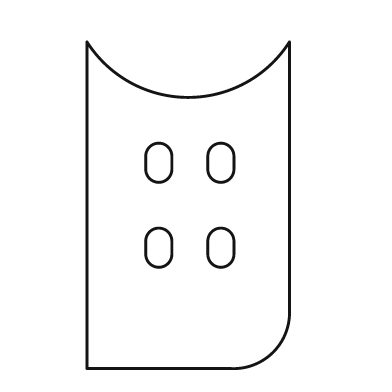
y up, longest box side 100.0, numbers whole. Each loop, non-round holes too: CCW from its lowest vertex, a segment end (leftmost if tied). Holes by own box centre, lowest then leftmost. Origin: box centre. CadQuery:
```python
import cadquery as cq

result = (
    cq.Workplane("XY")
    .moveTo(-31.0, -50.0)
    .lineTo(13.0, -50.0)
    .threePointArc((26.0, -45.0), (31.0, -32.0))
    .lineTo(31.0, 50.0)
    .threePointArc((0.0, 33.0), (-31.0, 50.0))
    .close()
    .moveTo(-13.0, -15.0)
    .threePointArc((-9.0, -19.0), (-5.0, -15.0))
    .lineTo(-5.0, -11.0)
    .threePointArc((-9.0, -7.0), (-13.0, -11.0))
    .close()
    .moveTo(6.0, -15.0)
    .threePointArc((10.0, -19.0), (14.0, -15.0))
    .lineTo(14.0, -11.0)
    .threePointArc((10.0, -7.0), (6.0, -11.0))
    .close()
    .moveTo(-13.0, 11.0)
    .threePointArc((-9.0, 7.0), (-5.0, 11.0))
    .lineTo(-5.0, 15.0)
    .threePointArc((-9.0, 19.0), (-13.0, 15.0))
    .close()
    .moveTo(6.0, 11.0)
    .threePointArc((10.0, 7.0), (14.0, 11.0))
    .lineTo(14.0, 15.0)
    .threePointArc((10.0, 19.0), (6.0, 15.0))
    .close()
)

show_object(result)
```